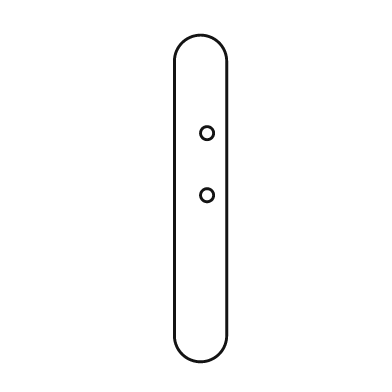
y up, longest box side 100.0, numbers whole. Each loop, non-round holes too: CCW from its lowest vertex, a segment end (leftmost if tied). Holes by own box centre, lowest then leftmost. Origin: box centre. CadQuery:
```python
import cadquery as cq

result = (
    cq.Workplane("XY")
    .moveTo(-8.0, -42.0)
    .threePointArc((0.0, -50.0), (8.0, -42.0))
    .lineTo(8.0, 42.0)
    .threePointArc((0.0, 50.0), (-8.0, 42.0))
    .close()
    .moveTo(2.0, 1.0)
    .circle(2.0)
    .moveTo(2.0, 20.0)
    .circle(2.0)
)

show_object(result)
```